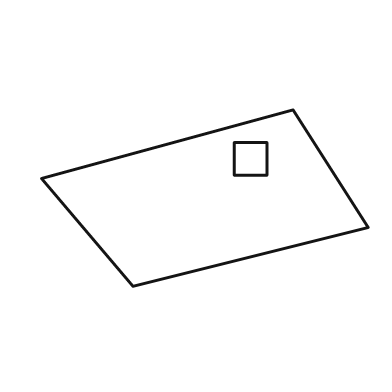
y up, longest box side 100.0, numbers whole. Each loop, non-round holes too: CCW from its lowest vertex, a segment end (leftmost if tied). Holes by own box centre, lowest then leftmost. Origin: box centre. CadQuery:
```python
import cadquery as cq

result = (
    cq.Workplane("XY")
    .moveTo(-22.0, -27.0)
    .lineTo(50.0, -9.0)
    .lineTo(27.0, 27.0)
    .lineTo(-50.0, 6.0)
    .close()
    .moveTo(9.0, 7.0)
    .lineTo(19.0, 7.0)
    .lineTo(19.0, 17.0)
    .lineTo(9.0, 17.0)
    .close()
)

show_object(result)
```